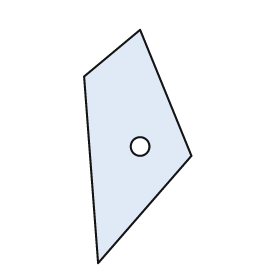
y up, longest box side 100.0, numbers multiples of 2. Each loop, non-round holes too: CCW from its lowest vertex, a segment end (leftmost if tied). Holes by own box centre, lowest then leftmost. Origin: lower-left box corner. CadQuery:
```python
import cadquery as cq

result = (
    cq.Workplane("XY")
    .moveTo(6.0, 0.0)
    .lineTo(46.0, 46.0)
    .lineTo(24.0, 100.0)
    .lineTo(0.0, 80.0)
    .close()
    .moveTo(24.0, 50.0)
    .circle(4.0)
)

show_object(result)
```